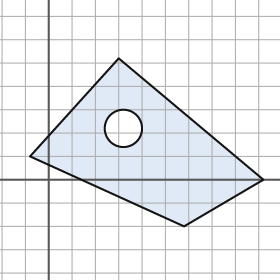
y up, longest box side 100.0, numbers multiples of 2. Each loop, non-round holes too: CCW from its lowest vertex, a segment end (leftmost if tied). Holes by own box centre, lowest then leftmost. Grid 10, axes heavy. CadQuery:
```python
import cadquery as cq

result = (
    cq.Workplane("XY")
    .moveTo(58.0, -20.0)
    .lineTo(92.0, 0.0)
    .lineTo(30.0, 52.0)
    .lineTo(-8.0, 10.0)
    .close()
    .moveTo(32.0, 22.0)
    .circle(8.0)
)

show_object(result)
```